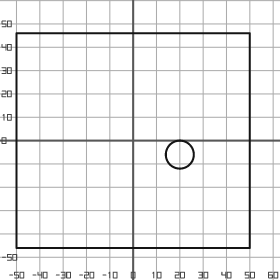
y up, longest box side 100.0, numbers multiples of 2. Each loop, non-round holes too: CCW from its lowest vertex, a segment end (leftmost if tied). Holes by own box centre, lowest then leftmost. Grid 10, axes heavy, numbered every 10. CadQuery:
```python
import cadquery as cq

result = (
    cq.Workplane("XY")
    .moveTo(-50.0, -46.0)
    .lineTo(50.0, -46.0)
    .lineTo(50.0, 46.0)
    .lineTo(-50.0, 46.0)
    .close()
    .moveTo(20.0, -6.0)
    .circle(6.0)
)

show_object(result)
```